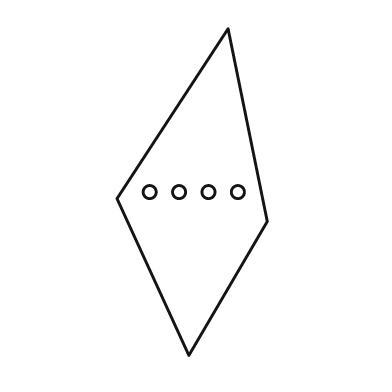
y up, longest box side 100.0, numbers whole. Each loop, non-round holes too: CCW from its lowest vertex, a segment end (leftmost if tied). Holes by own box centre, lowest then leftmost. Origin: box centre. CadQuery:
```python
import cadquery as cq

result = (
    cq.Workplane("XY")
    .moveTo(-1.0, -50.0)
    .lineTo(23.0, -9.0)
    .lineTo(11.0, 50.0)
    .lineTo(-23.0, -2.0)
    .close()
    .moveTo(-13.0, 0.0)
    .circle(2.0)
    .moveTo(-4.0, 0.0)
    .circle(2.0)
    .moveTo(5.0, 0.0)
    .circle(2.0)
    .moveTo(14.0, 0.0)
    .circle(2.0)
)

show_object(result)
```